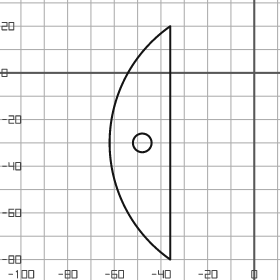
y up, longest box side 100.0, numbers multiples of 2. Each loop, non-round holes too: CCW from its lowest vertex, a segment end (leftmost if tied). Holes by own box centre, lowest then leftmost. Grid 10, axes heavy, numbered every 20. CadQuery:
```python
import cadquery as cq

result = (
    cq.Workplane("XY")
    .moveTo(-36.0, -80.0)
    .lineTo(-36.0, 20.0)
    .threePointArc((-62.0, -30.0), (-36.0, -80.0))
    .close()
    .moveTo(-48.0, -30.0)
    .circle(4.0)
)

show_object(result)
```